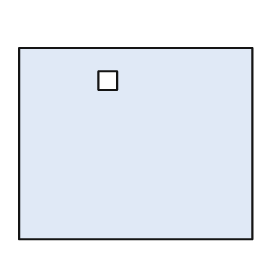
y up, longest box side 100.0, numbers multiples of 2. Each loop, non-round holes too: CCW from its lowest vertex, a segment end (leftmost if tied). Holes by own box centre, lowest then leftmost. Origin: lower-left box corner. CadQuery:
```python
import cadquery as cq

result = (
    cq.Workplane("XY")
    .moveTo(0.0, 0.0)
    .lineTo(100.0, 0.0)
    .lineTo(100.0, 82.0)
    .lineTo(0.0, 82.0)
    .close()
    .moveTo(34.0, 64.0)
    .lineTo(42.0, 64.0)
    .lineTo(42.0, 72.0)
    .lineTo(34.0, 72.0)
    .close()
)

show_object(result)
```